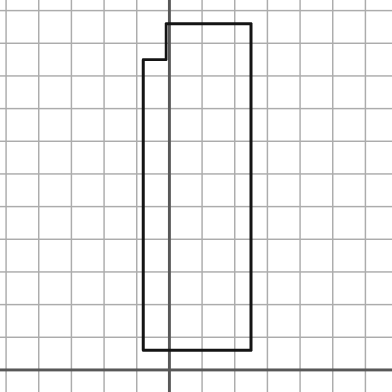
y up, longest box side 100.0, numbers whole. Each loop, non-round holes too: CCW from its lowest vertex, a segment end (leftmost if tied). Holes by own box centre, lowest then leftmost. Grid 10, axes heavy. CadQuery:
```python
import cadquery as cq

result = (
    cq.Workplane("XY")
    .moveTo(-8.0, 6.0)
    .lineTo(25.0, 6.0)
    .lineTo(25.0, 106.0)
    .lineTo(-1.0, 106.0)
    .lineTo(-1.0, 95.0)
    .lineTo(-8.0, 95.0)
    .close()
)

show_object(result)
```